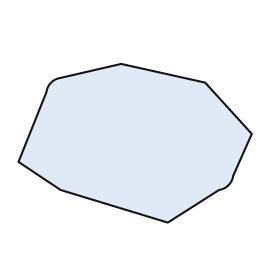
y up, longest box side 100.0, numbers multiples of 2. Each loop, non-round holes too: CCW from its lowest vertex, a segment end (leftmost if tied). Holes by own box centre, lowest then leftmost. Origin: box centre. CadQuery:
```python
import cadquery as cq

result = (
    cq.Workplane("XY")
    .moveTo(14.0, -34.0)
    .lineTo(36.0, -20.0)
    .threePointArc((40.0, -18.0), (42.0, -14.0))
    .lineTo(50.0, 4.0)
    .lineTo(30.0, 26.0)
    .lineTo(-6.0, 34.0)
    .lineTo(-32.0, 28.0)
    .threePointArc((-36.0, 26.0), (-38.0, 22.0))
    .lineTo(-50.0, -8.0)
    .lineTo(-32.0, -20.0)
    .close()
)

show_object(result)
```